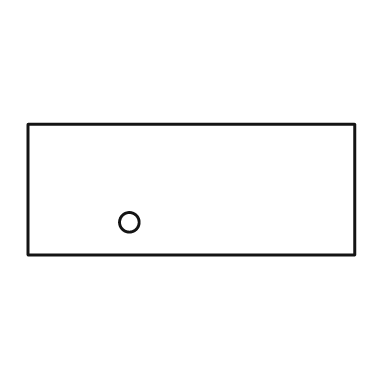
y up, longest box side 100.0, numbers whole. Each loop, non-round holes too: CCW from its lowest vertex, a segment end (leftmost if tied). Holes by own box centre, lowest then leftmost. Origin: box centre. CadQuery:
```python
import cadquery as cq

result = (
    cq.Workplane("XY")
    .moveTo(-50.0, -20.0)
    .lineTo(50.0, -20.0)
    .lineTo(50.0, 20.0)
    .lineTo(-50.0, 20.0)
    .close()
    .moveTo(-19.0, -10.0)
    .circle(3.0)
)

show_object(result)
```